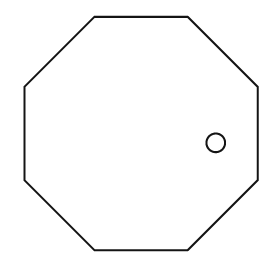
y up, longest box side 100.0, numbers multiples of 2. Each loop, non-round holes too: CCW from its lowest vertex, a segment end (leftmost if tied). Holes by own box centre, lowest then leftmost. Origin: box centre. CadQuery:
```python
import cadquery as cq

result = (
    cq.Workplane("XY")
    .moveTo(-20.0, -50.0)
    .lineTo(20.0, -50.0)
    .lineTo(50.0, -20.0)
    .lineTo(50.0, 20.0)
    .lineTo(20.0, 50.0)
    .lineTo(-20.0, 50.0)
    .lineTo(-50.0, 20.0)
    .lineTo(-50.0, -20.0)
    .close()
    .moveTo(32.0, -4.0)
    .circle(4.0)
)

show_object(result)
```